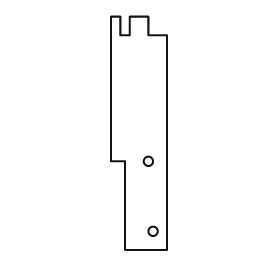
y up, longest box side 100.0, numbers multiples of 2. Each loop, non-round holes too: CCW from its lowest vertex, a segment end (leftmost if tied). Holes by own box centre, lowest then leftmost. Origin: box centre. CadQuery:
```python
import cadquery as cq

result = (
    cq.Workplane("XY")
    .moveTo(-6.0, -50.0)
    .lineTo(12.0, -50.0)
    .lineTo(12.0, 42.0)
    .lineTo(4.0, 42.0)
    .lineTo(4.0, 50.0)
    .lineTo(-4.0, 50.0)
    .lineTo(-4.0, 42.0)
    .lineTo(-8.0, 42.0)
    .lineTo(-8.0, 50.0)
    .lineTo(-12.0, 50.0)
    .lineTo(-12.0, -12.0)
    .lineTo(-6.0, -12.0)
    .close()
    .moveTo(6.0, -42.0)
    .circle(2.0)
    .moveTo(4.0, -12.0)
    .circle(2.0)
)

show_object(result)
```